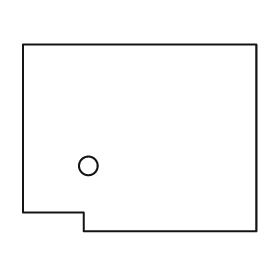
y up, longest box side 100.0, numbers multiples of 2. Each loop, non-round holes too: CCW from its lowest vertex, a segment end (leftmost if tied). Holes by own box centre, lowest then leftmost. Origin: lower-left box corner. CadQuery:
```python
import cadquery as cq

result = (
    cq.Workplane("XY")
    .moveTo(26.0, 0.0)
    .lineTo(100.0, 0.0)
    .lineTo(100.0, 80.0)
    .lineTo(0.0, 80.0)
    .lineTo(0.0, 8.0)
    .lineTo(26.0, 8.0)
    .close()
    .moveTo(28.0, 28.0)
    .circle(4.0)
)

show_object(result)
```